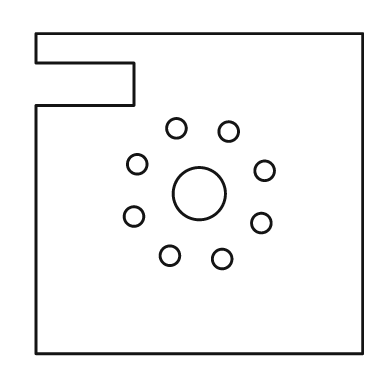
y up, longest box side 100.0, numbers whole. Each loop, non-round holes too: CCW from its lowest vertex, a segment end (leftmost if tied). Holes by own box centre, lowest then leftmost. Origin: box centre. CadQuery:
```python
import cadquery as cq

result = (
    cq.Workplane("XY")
    .moveTo(-50.0, -49.0)
    .lineTo(50.0, -49.0)
    .lineTo(50.0, 49.0)
    .lineTo(-50.0, 49.0)
    .lineTo(-50.0, 40.0)
    .lineTo(-20.0, 40.0)
    .lineTo(-20.0, 27.0)
    .lineTo(-50.0, 27.0)
    .close()
    .moveTo(7.0, -20.0)
    .circle(3.0)
    .moveTo(-9.0, -19.0)
    .circle(3.0)
    .moveTo(19.0, -9.0)
    .circle(3.0)
    .moveTo(-20.0, -7.0)
    .circle(3.0)
    .moveTo(0.0, 0.0)
    .circle(8.0)
    .moveTo(20.0, 7.0)
    .circle(3.0)
    .moveTo(-19.0, 9.0)
    .circle(3.0)
    .moveTo(9.0, 19.0)
    .circle(3.0)
    .moveTo(-7.0, 20.0)
    .circle(3.0)
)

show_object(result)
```